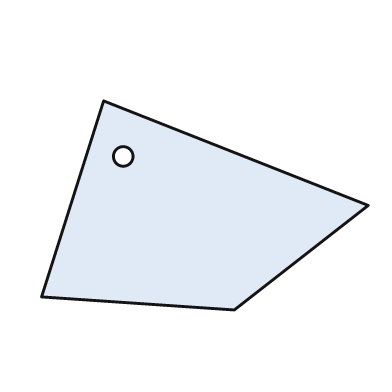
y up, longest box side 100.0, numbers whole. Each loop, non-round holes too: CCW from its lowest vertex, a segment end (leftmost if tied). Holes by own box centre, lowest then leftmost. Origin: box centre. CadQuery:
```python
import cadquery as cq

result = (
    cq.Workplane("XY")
    .moveTo(9.0, -32.0)
    .lineTo(50.0, 0.0)
    .lineTo(-31.0, 32.0)
    .lineTo(-50.0, -28.0)
    .close()
    .moveTo(-25.0, 15.0)
    .circle(3.0)
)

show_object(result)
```